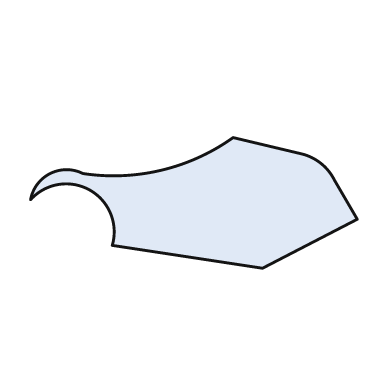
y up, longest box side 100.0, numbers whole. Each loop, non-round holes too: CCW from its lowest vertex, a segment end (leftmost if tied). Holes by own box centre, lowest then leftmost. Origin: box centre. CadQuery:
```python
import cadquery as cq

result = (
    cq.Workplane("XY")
    .moveTo(21.0, -20.0)
    .lineTo(50.0, -5.0)
    .lineTo(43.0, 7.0)
    .threePointArc((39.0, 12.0), (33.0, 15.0))
    .lineTo(12.0, 20.0)
    .threePointArc((-10.0, 10.0), (-34.0, 9.0))
    .threePointArc((-44.0, 9.0), (-50.0, 1.0))
    .threePointArc((-32.0, 4.0), (-25.0, -13.0))
    .close()
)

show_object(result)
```